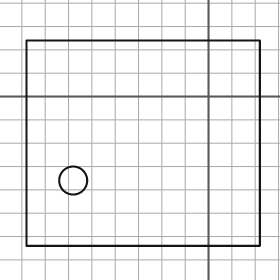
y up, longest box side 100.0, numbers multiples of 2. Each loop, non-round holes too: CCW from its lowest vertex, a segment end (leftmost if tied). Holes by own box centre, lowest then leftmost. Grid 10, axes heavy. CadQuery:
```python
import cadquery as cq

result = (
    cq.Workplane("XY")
    .moveTo(-78.0, -64.0)
    .lineTo(22.0, -64.0)
    .lineTo(22.0, 24.0)
    .lineTo(-78.0, 24.0)
    .close()
    .moveTo(-58.0, -36.0)
    .circle(6.0)
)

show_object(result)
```